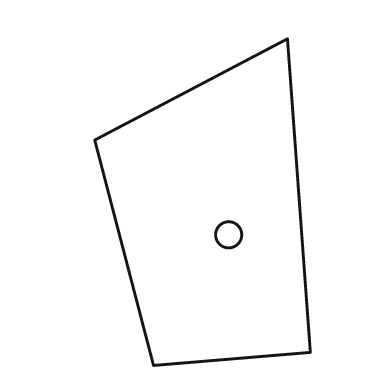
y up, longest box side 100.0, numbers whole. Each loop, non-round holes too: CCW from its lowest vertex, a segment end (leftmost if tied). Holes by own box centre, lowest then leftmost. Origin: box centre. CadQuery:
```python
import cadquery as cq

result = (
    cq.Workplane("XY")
    .moveTo(-15.0, -50.0)
    .lineTo(33.0, -46.0)
    .lineTo(26.0, 50.0)
    .lineTo(-33.0, 19.0)
    .close()
    .moveTo(8.0, -10.0)
    .circle(4.0)
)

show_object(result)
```